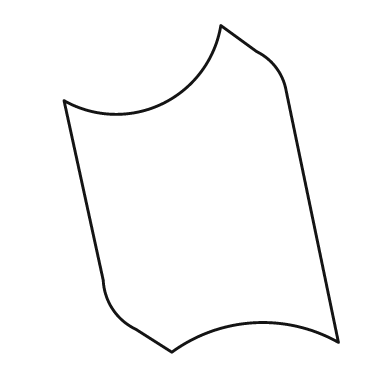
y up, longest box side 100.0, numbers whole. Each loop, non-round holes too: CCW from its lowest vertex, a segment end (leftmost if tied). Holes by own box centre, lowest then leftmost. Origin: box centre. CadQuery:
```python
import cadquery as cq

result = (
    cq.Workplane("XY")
    .moveTo(-9.0, -50.0)
    .threePointArc((16.0, -41.0), (42.0, -47.0))
    .lineTo(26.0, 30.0)
    .threePointArc((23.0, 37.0), (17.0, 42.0))
    .lineTo(6.0, 50.0)
    .threePointArc((-12.0, 26.0), (-42.0, 27.0))
    .lineTo(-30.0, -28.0)
    .threePointArc((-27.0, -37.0), (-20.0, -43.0))
    .close()
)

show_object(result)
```